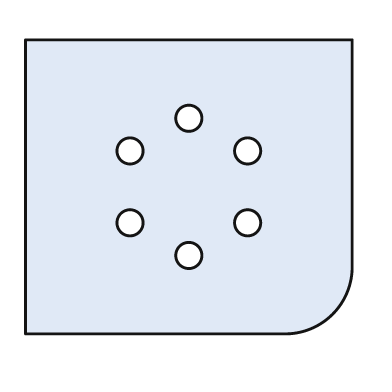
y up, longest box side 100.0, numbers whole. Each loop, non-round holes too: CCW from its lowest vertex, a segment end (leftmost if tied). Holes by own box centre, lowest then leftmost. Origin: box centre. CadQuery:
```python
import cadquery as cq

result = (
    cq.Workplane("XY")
    .moveTo(-50.0, -45.0)
    .lineTo(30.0, -45.0)
    .threePointArc((44.0, -39.0), (50.0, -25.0))
    .lineTo(50.0, 45.0)
    .lineTo(-50.0, 45.0)
    .close()
    .moveTo(0.0, -21.0)
    .circle(4.0)
    .moveTo(-18.0, -11.0)
    .circle(4.0)
    .moveTo(18.0, -11.0)
    .circle(4.0)
    .moveTo(-18.0, 11.0)
    .circle(4.0)
    .moveTo(18.0, 11.0)
    .circle(4.0)
    .moveTo(0.0, 21.0)
    .circle(4.0)
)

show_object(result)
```